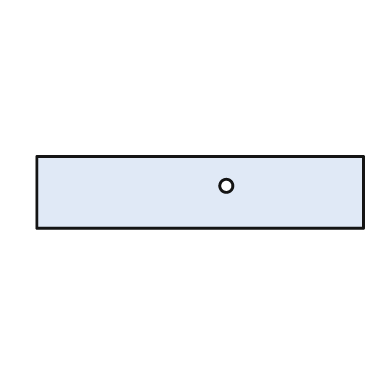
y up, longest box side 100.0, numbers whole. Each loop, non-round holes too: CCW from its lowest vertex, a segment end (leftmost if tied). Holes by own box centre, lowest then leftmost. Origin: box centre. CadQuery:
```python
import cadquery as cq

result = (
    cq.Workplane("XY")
    .moveTo(-50.0, -11.0)
    .lineTo(50.0, -11.0)
    .lineTo(50.0, 11.0)
    .lineTo(-50.0, 11.0)
    .close()
    .moveTo(8.0, 2.0)
    .circle(2.0)
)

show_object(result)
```